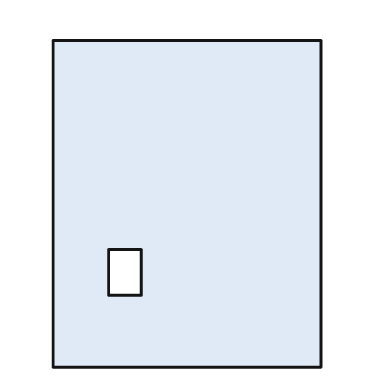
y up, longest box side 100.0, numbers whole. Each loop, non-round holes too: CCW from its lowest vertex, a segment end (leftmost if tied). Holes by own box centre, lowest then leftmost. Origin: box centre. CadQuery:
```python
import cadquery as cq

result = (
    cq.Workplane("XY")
    .moveTo(-41.0, -50.0)
    .lineTo(41.0, -50.0)
    .lineTo(41.0, 50.0)
    .lineTo(-41.0, 50.0)
    .close()
    .moveTo(-24.0, -28.0)
    .lineTo(-14.0, -28.0)
    .lineTo(-14.0, -14.0)
    .lineTo(-24.0, -14.0)
    .close()
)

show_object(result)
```